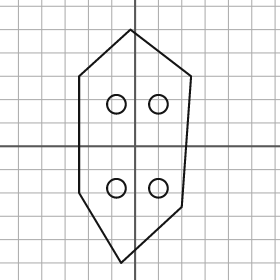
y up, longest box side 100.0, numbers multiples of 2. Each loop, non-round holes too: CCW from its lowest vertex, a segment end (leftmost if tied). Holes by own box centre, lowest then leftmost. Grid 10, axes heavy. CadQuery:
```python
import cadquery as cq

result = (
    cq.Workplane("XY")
    .moveTo(-6.0, -50.0)
    .lineTo(20.0, -26.0)
    .lineTo(24.0, 30.0)
    .lineTo(-2.0, 50.0)
    .lineTo(-24.0, 30.0)
    .lineTo(-24.0, -20.0)
    .close()
    .moveTo(-8.0, -18.0)
    .circle(4.0)
    .moveTo(10.0, -18.0)
    .circle(4.0)
    .moveTo(-8.0, 18.0)
    .circle(4.0)
    .moveTo(10.0, 18.0)
    .circle(4.0)
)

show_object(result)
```